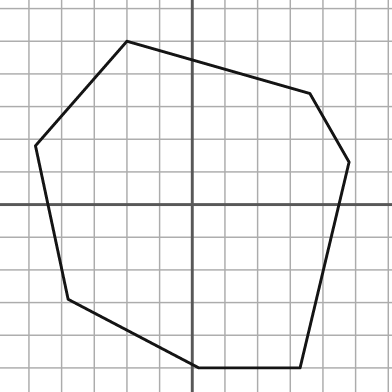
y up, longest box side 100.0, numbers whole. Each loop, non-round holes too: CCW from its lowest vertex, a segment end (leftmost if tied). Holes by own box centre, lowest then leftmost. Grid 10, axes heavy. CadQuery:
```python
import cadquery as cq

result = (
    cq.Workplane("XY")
    .moveTo(2.0, -50.0)
    .lineTo(33.0, -50.0)
    .lineTo(48.0, 13.0)
    .lineTo(36.0, 34.0)
    .lineTo(-20.0, 50.0)
    .lineTo(-48.0, 18.0)
    .lineTo(-38.0, -29.0)
    .close()
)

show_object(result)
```